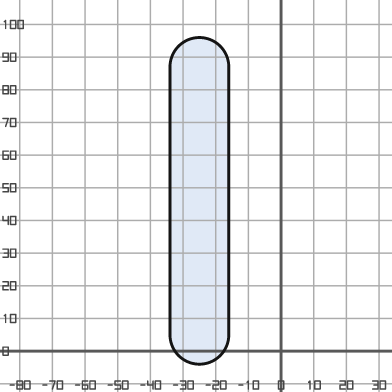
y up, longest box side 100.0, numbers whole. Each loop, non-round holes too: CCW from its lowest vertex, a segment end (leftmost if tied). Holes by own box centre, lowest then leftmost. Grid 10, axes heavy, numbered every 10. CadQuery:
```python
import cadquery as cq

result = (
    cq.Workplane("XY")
    .moveTo(-34.0, 5.0)
    .threePointArc((-25.0, -4.0), (-16.0, 5.0))
    .lineTo(-16.0, 87.0)
    .threePointArc((-25.0, 96.0), (-34.0, 87.0))
    .close()
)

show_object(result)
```